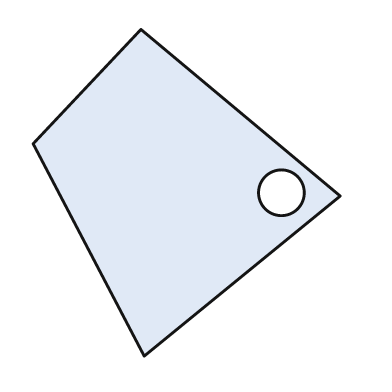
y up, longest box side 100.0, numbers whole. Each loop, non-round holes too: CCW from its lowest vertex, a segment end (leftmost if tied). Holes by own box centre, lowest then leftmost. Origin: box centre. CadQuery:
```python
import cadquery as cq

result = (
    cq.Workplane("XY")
    .moveTo(-13.0, -50.0)
    .lineTo(47.0, -1.0)
    .lineTo(-14.0, 50.0)
    .lineTo(-47.0, 15.0)
    .close()
    .moveTo(29.0, 0.0)
    .circle(7.0)
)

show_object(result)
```